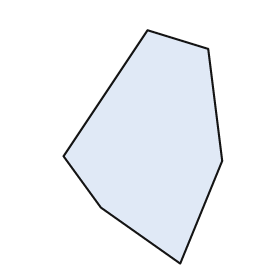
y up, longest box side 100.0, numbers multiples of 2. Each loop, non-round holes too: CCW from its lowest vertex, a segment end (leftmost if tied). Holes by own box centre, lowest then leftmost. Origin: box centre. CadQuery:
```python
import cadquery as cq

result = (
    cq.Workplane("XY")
    .moveTo(16.0, -50.0)
    .lineTo(34.0, -6.0)
    .lineTo(28.0, 42.0)
    .lineTo(2.0, 50.0)
    .lineTo(-34.0, -4.0)
    .lineTo(-18.0, -26.0)
    .close()
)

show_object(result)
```